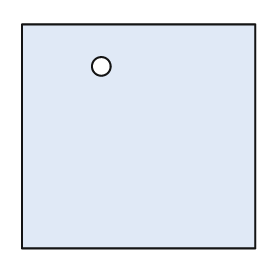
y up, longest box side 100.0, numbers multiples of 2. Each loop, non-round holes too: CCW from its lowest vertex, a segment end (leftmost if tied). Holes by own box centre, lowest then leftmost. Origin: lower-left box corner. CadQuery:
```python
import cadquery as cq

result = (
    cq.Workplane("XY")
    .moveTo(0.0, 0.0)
    .lineTo(100.0, 0.0)
    .lineTo(100.0, 96.0)
    .lineTo(0.0, 96.0)
    .close()
    .moveTo(34.0, 78.0)
    .circle(4.0)
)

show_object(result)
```